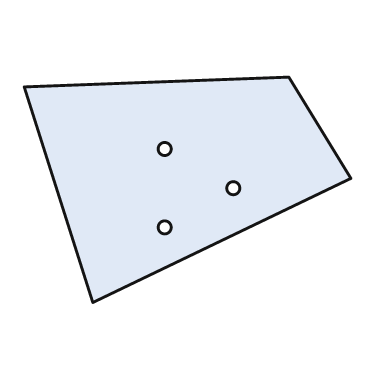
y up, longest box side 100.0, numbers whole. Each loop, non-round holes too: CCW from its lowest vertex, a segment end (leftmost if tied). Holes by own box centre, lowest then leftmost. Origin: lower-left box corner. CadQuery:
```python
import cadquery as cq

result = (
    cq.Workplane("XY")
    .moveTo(21.0, 0.0)
    .lineTo(100.0, 38.0)
    .lineTo(81.0, 69.0)
    .lineTo(0.0, 66.0)
    .close()
    .moveTo(43.0, 23.0)
    .circle(2.0)
    .moveTo(64.0, 35.0)
    .circle(2.0)
    .moveTo(43.0, 47.0)
    .circle(2.0)
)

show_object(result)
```